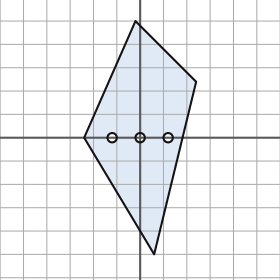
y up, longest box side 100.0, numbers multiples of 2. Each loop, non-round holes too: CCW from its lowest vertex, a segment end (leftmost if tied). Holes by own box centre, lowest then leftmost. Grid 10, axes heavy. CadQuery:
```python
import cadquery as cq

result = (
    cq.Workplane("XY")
    .moveTo(6.0, -50.0)
    .lineTo(24.0, 24.0)
    .lineTo(-2.0, 50.0)
    .lineTo(-24.0, 0.0)
    .close()
    .moveTo(-12.0, 0.0)
    .circle(2.0)
    .moveTo(0.0, 0.0)
    .circle(2.0)
    .moveTo(12.0, 0.0)
    .circle(2.0)
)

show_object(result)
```